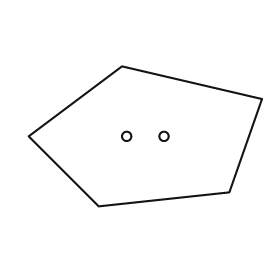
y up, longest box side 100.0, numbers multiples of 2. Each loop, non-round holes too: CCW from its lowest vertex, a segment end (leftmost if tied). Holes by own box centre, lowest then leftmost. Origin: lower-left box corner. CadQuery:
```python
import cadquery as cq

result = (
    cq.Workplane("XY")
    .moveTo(30.0, 0.0)
    .lineTo(86.0, 6.0)
    .lineTo(100.0, 46.0)
    .lineTo(40.0, 60.0)
    .lineTo(0.0, 30.0)
    .close()
    .moveTo(42.0, 30.0)
    .circle(2.0)
    .moveTo(58.0, 30.0)
    .circle(2.0)
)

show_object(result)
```